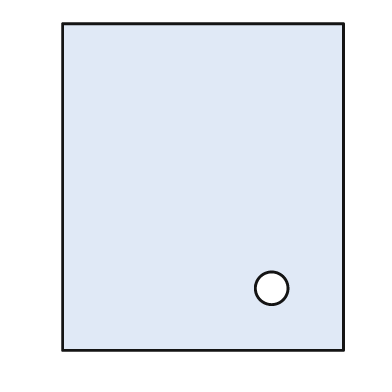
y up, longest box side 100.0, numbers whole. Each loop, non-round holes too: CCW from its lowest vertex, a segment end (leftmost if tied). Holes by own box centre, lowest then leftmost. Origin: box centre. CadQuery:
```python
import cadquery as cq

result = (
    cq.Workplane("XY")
    .moveTo(-43.0, -50.0)
    .lineTo(43.0, -50.0)
    .lineTo(43.0, 50.0)
    .lineTo(-43.0, 50.0)
    .close()
    .moveTo(21.0, -31.0)
    .circle(5.0)
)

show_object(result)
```